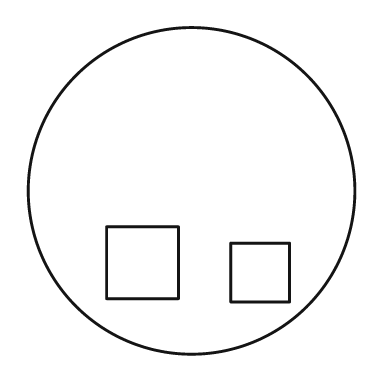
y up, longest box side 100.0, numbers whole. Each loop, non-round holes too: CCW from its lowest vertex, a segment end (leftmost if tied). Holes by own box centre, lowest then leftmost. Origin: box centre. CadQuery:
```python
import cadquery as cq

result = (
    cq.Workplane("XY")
    .moveTo(0.0, 0.0)
    .circle(50.0)
    .moveTo(12.0, -34.0)
    .lineTo(30.0, -34.0)
    .lineTo(30.0, -16.0)
    .lineTo(12.0, -16.0)
    .close()
    .moveTo(-26.0, -33.0)
    .lineTo(-4.0, -33.0)
    .lineTo(-4.0, -11.0)
    .lineTo(-26.0, -11.0)
    .close()
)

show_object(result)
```